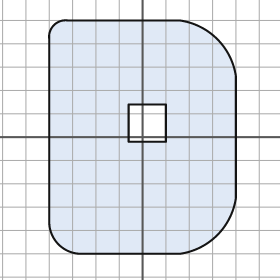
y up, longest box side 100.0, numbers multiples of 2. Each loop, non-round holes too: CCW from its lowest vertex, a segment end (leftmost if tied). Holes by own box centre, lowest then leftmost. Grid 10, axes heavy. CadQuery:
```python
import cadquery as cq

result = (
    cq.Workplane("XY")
    .moveTo(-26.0, -50.0)
    .lineTo(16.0, -50.0)
    .threePointArc((32.0, -42.0), (40.0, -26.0))
    .lineTo(40.0, 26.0)
    .threePointArc((32.0, 42.0), (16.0, 50.0))
    .lineTo(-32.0, 50.0)
    .threePointArc((-38.0, 48.0), (-40.0, 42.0))
    .lineTo(-40.0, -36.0)
    .threePointArc((-36.0, -46.0), (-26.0, -50.0))
    .close()
    .moveTo(-6.0, -2.0)
    .lineTo(10.0, -2.0)
    .lineTo(10.0, 14.0)
    .lineTo(-6.0, 14.0)
    .close()
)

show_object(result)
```